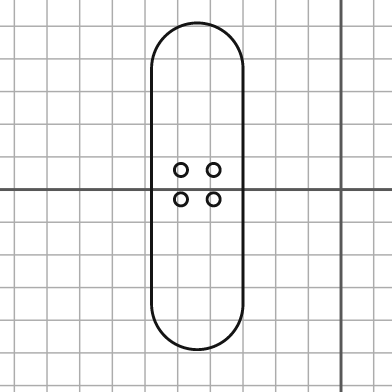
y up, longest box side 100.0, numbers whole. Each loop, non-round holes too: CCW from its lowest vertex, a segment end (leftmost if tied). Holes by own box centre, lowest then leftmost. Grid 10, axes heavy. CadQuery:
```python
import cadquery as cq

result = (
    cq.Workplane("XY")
    .moveTo(-58.0, -35.0)
    .threePointArc((-44.0, -49.0), (-30.0, -35.0))
    .lineTo(-30.0, 37.0)
    .threePointArc((-44.0, 51.0), (-58.0, 37.0))
    .close()
    .moveTo(-49.0, -3.0)
    .circle(2.0)
    .moveTo(-39.0, -3.0)
    .circle(2.0)
    .moveTo(-49.0, 6.0)
    .circle(2.0)
    .moveTo(-39.0, 6.0)
    .circle(2.0)
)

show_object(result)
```